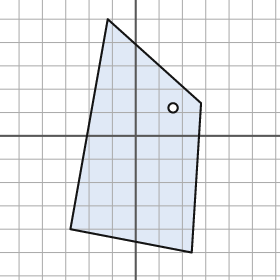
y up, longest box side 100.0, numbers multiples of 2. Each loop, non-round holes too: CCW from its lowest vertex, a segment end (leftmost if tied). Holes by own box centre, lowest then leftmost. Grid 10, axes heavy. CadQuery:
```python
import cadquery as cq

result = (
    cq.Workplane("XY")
    .moveTo(24.0, -50.0)
    .lineTo(28.0, 14.0)
    .lineTo(-12.0, 50.0)
    .lineTo(-28.0, -40.0)
    .close()
    .moveTo(16.0, 12.0)
    .circle(2.0)
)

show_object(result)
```